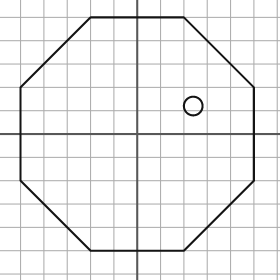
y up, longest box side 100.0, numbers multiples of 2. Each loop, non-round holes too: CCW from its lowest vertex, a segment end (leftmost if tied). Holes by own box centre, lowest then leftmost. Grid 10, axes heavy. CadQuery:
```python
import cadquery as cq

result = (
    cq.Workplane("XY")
    .moveTo(-20.0, -50.0)
    .lineTo(20.0, -50.0)
    .lineTo(50.0, -20.0)
    .lineTo(50.0, 20.0)
    .lineTo(20.0, 50.0)
    .lineTo(-20.0, 50.0)
    .lineTo(-50.0, 20.0)
    .lineTo(-50.0, -20.0)
    .close()
    .moveTo(24.0, 12.0)
    .circle(4.0)
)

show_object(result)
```